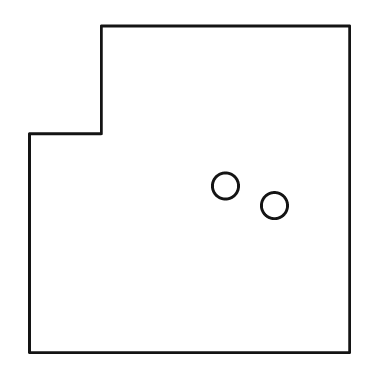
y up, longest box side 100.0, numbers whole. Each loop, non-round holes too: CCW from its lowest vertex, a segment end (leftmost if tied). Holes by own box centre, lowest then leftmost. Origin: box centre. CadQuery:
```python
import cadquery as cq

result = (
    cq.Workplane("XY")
    .moveTo(-49.0, -50.0)
    .lineTo(49.0, -50.0)
    .lineTo(49.0, 50.0)
    .lineTo(-27.0, 50.0)
    .lineTo(-27.0, 17.0)
    .lineTo(-49.0, 17.0)
    .close()
    .moveTo(26.0, -5.0)
    .circle(4.0)
    .moveTo(11.0, 1.0)
    .circle(4.0)
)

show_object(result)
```